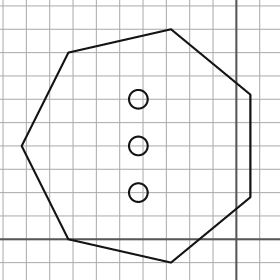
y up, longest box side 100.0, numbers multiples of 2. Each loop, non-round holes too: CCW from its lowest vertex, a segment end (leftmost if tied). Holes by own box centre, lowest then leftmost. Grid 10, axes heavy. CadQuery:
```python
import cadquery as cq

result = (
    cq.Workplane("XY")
    .moveTo(-28.0, -10.0)
    .lineTo(6.0, 18.0)
    .lineTo(6.0, 62.0)
    .lineTo(-28.0, 90.0)
    .lineTo(-72.0, 80.0)
    .lineTo(-92.0, 40.0)
    .lineTo(-72.0, 0.0)
    .close()
    .moveTo(-42.0, 20.0)
    .circle(4.0)
    .moveTo(-42.0, 40.0)
    .circle(4.0)
    .moveTo(-42.0, 60.0)
    .circle(4.0)
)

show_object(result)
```